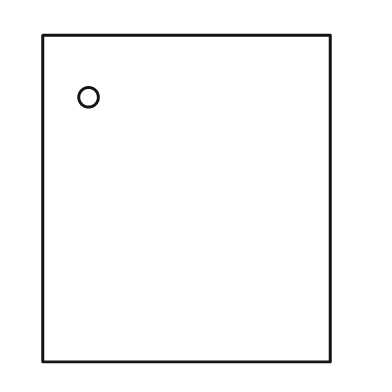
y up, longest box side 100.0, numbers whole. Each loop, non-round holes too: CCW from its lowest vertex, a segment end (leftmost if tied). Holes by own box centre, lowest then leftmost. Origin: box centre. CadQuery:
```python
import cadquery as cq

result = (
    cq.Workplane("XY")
    .moveTo(-44.0, -50.0)
    .lineTo(44.0, -50.0)
    .lineTo(44.0, 50.0)
    .lineTo(-44.0, 50.0)
    .close()
    .moveTo(-30.0, 31.0)
    .circle(3.0)
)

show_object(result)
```